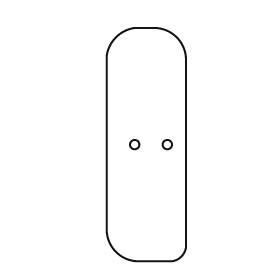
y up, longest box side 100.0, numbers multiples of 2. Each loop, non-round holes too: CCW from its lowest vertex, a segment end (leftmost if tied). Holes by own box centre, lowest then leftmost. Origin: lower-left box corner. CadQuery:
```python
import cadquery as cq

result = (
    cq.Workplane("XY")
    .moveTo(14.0, 0.0)
    .lineTo(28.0, 0.0)
    .threePointArc((32.0, 2.0), (34.0, 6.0))
    .lineTo(34.0, 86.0)
    .threePointArc((30.0, 96.0), (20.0, 100.0))
    .lineTo(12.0, 100.0)
    .threePointArc((4.0, 96.0), (0.0, 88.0))
    .lineTo(0.0, 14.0)
    .threePointArc((4.0, 4.0), (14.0, 0.0))
    .close()
    .moveTo(12.0, 50.0)
    .circle(2.0)
    .moveTo(26.0, 50.0)
    .circle(2.0)
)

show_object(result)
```